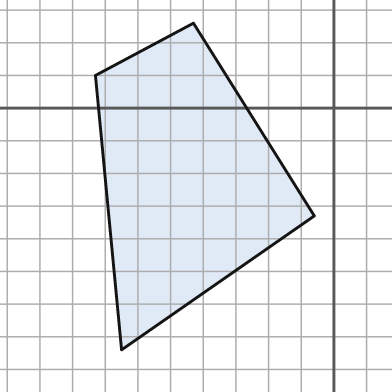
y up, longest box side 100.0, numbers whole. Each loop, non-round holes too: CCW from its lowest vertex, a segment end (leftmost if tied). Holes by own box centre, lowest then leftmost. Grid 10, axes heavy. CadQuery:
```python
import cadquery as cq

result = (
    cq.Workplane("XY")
    .moveTo(-65.0, -74.0)
    .lineTo(-6.0, -33.0)
    .lineTo(-43.0, 26.0)
    .lineTo(-73.0, 10.0)
    .close()
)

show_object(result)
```